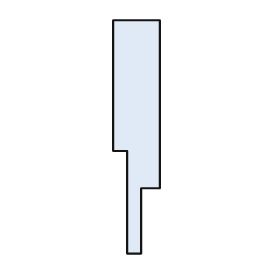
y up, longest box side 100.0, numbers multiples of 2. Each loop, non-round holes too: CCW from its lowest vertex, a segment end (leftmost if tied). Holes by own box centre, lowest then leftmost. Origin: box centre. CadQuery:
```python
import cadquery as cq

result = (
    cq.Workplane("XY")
    .moveTo(-4.0, -50.0)
    .lineTo(2.0, -50.0)
    .lineTo(2.0, -22.0)
    .lineTo(10.0, -22.0)
    .lineTo(10.0, 50.0)
    .lineTo(-10.0, 50.0)
    .lineTo(-10.0, -6.0)
    .lineTo(-4.0, -6.0)
    .close()
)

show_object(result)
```